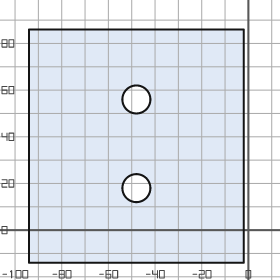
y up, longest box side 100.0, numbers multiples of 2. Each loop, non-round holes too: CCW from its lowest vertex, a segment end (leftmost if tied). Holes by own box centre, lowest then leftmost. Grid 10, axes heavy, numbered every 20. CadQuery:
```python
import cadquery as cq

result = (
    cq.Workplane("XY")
    .moveTo(-94.0, -14.0)
    .lineTo(-2.0, -14.0)
    .lineTo(-2.0, 86.0)
    .lineTo(-94.0, 86.0)
    .close()
    .moveTo(-48.0, 18.0)
    .circle(6.0)
    .moveTo(-48.0, 56.0)
    .circle(6.0)
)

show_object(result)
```